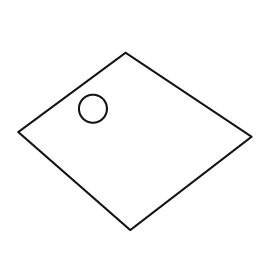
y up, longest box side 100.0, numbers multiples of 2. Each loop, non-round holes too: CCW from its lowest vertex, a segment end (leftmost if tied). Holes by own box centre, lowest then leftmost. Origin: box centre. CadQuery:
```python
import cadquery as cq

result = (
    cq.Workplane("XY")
    .moveTo(-2.0, -38.0)
    .lineTo(50.0, 2.0)
    .lineTo(-4.0, 38.0)
    .lineTo(-50.0, 4.0)
    .close()
    .moveTo(-18.0, 14.0)
    .circle(6.0)
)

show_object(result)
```